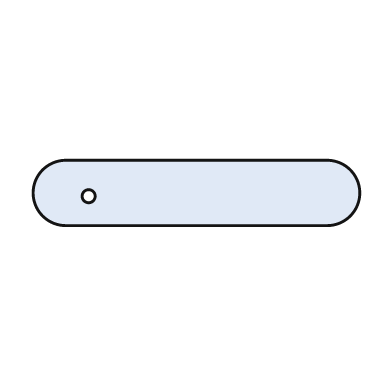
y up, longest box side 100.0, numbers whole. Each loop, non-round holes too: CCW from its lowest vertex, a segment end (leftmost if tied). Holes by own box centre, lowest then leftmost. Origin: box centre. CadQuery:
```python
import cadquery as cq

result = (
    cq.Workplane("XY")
    .moveTo(-40.0, -10.0)
    .lineTo(40.0, -10.0)
    .threePointArc((50.0, 0.0), (40.0, 10.0))
    .lineTo(-40.0, 10.0)
    .threePointArc((-50.0, 0.0), (-40.0, -10.0))
    .close()
    .moveTo(-33.0, -1.0)
    .circle(2.0)
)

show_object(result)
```